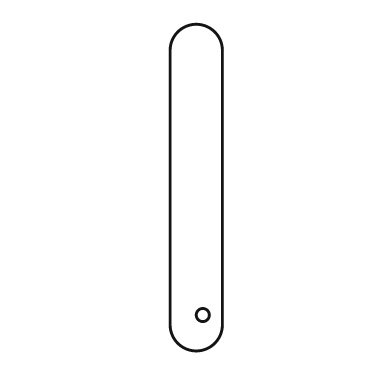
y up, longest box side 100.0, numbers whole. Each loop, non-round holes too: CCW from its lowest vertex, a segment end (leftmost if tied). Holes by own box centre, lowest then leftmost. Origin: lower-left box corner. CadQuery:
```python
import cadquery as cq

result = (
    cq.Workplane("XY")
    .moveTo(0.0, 8.0)
    .threePointArc((8.0, 0.0), (16.0, 8.0))
    .lineTo(16.0, 92.0)
    .threePointArc((8.0, 100.0), (0.0, 92.0))
    .close()
    .moveTo(10.0, 11.0)
    .circle(2.0)
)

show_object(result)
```